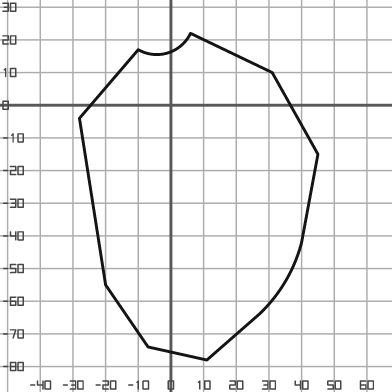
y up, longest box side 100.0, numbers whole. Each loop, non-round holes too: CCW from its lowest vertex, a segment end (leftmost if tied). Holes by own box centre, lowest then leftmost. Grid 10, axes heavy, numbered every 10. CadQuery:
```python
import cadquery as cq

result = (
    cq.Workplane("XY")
    .moveTo(11.0, -78.0)
    .lineTo(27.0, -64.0)
    .threePointArc((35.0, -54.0), (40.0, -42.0))
    .lineTo(45.0, -15.0)
    .lineTo(31.0, 10.0)
    .lineTo(6.0, 22.0)
    .threePointArc((-1.0, 16.0), (-10.0, 17.0))
    .lineTo(-28.0, -4.0)
    .lineTo(-20.0, -55.0)
    .lineTo(-7.0, -74.0)
    .close()
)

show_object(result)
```